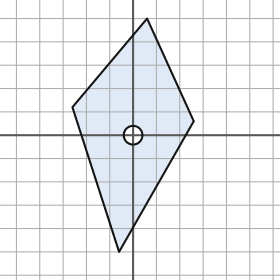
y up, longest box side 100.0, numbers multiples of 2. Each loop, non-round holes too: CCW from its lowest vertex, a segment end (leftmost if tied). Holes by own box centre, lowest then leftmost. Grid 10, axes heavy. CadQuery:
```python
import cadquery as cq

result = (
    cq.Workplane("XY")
    .moveTo(-6.0, -50.0)
    .lineTo(26.0, 6.0)
    .lineTo(6.0, 50.0)
    .lineTo(-26.0, 12.0)
    .close()
    .moveTo(0.0, 0.0)
    .circle(4.0)
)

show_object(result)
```